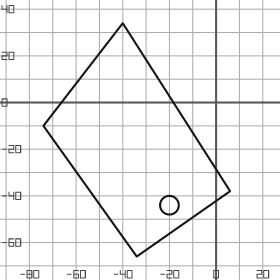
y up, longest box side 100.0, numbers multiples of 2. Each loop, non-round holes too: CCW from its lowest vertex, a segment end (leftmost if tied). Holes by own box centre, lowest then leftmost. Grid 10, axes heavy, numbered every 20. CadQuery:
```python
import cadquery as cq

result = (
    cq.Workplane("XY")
    .moveTo(-34.0, -66.0)
    .lineTo(6.0, -38.0)
    .lineTo(-40.0, 34.0)
    .lineTo(-74.0, -10.0)
    .close()
    .moveTo(-20.0, -44.0)
    .circle(4.0)
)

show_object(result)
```